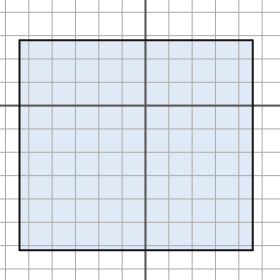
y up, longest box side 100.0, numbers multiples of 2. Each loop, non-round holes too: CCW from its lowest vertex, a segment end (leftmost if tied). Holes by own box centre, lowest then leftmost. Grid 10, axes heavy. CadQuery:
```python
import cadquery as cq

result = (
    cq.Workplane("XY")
    .moveTo(-54.0, -62.0)
    .lineTo(46.0, -62.0)
    .lineTo(46.0, 28.0)
    .lineTo(-54.0, 28.0)
    .close()
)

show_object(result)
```